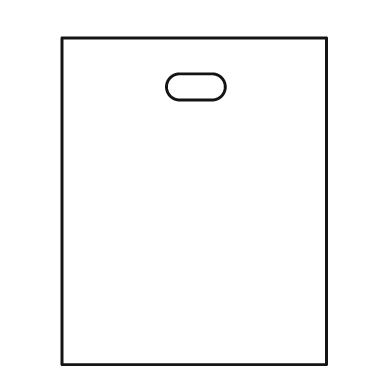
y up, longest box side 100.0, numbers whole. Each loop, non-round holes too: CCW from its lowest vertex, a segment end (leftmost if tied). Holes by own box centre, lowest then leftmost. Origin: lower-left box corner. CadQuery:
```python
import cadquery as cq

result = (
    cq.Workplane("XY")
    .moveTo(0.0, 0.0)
    .lineTo(81.0, 0.0)
    .lineTo(81.0, 100.0)
    .lineTo(0.0, 100.0)
    .close()
    .moveTo(36.0, 81.0)
    .lineTo(46.0, 81.0)
    .threePointArc((50.0, 85.0), (46.0, 89.0))
    .lineTo(36.0, 89.0)
    .threePointArc((32.0, 85.0), (36.0, 81.0))
    .close()
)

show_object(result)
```